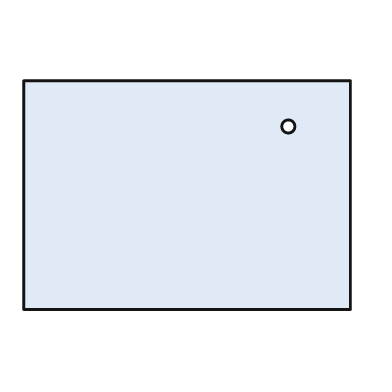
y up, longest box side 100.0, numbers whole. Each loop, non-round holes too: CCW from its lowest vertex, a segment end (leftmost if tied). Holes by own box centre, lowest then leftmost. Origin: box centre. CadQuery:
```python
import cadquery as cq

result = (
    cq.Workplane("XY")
    .moveTo(-50.0, -35.0)
    .lineTo(50.0, -35.0)
    .lineTo(50.0, 35.0)
    .lineTo(-50.0, 35.0)
    .close()
    .moveTo(31.0, 21.0)
    .circle(2.0)
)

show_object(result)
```